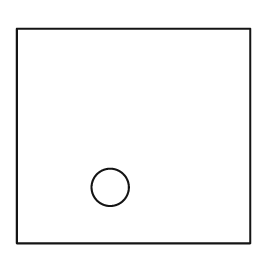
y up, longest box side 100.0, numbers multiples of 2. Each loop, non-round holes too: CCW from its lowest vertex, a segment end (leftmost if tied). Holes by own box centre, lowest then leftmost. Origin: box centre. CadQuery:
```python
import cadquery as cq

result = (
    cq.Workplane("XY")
    .moveTo(-50.0, -46.0)
    .lineTo(50.0, -46.0)
    .lineTo(50.0, 46.0)
    .lineTo(-50.0, 46.0)
    .close()
    .moveTo(-10.0, -22.0)
    .circle(8.0)
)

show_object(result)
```